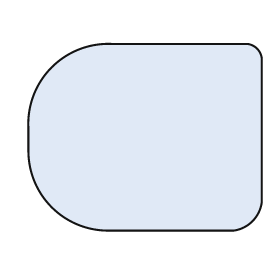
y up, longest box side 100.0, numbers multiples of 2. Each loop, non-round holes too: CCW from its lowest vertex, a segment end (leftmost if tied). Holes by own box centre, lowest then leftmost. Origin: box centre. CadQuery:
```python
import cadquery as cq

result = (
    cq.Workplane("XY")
    .moveTo(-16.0, -40.0)
    .lineTo(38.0, -40.0)
    .threePointArc((46.0, -36.0), (50.0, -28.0))
    .lineTo(50.0, 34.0)
    .threePointArc((48.0, 38.0), (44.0, 40.0))
    .lineTo(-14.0, 40.0)
    .threePointArc((-40.0, 30.0), (-50.0, 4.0))
    .lineTo(-50.0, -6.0)
    .threePointArc((-40.0, -30.0), (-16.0, -40.0))
    .close()
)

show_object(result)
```